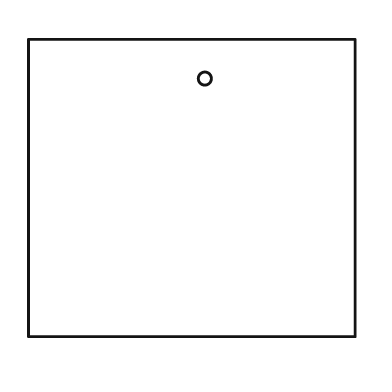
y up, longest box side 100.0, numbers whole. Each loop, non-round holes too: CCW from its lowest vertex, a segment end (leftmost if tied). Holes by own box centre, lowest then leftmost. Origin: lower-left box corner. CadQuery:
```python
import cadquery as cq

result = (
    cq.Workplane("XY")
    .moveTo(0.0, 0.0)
    .lineTo(100.0, 0.0)
    .lineTo(100.0, 91.0)
    .lineTo(0.0, 91.0)
    .close()
    .moveTo(54.0, 79.0)
    .circle(2.0)
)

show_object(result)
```